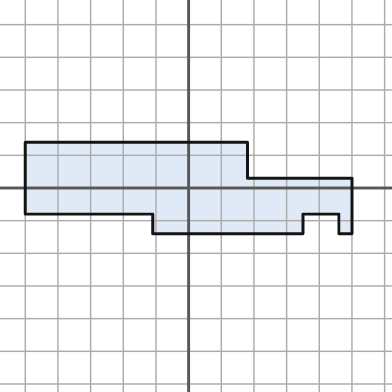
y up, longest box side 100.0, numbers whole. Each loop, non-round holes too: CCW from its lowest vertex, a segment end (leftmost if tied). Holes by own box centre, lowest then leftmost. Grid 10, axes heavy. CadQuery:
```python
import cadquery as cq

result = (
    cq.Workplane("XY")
    .moveTo(-11.0, -14.0)
    .lineTo(35.0, -14.0)
    .lineTo(35.0, -8.0)
    .lineTo(46.0, -8.0)
    .lineTo(46.0, -14.0)
    .lineTo(50.0, -14.0)
    .lineTo(50.0, 3.0)
    .lineTo(18.0, 3.0)
    .lineTo(18.0, 14.0)
    .lineTo(-50.0, 14.0)
    .lineTo(-50.0, -8.0)
    .lineTo(-11.0, -8.0)
    .close()
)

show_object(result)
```